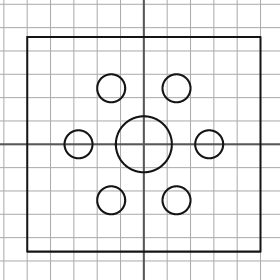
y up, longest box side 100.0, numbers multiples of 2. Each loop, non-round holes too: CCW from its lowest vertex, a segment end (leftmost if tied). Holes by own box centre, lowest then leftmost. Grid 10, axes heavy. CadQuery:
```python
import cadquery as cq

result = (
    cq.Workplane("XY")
    .moveTo(-50.0, -46.0)
    .lineTo(50.0, -46.0)
    .lineTo(50.0, 46.0)
    .lineTo(-50.0, 46.0)
    .close()
    .moveTo(-14.0, -24.0)
    .circle(6.0)
    .moveTo(14.0, -24.0)
    .circle(6.0)
    .moveTo(-28.0, 0.0)
    .circle(6.0)
    .moveTo(0.0, 0.0)
    .circle(12.0)
    .moveTo(28.0, 0.0)
    .circle(6.0)
    .moveTo(-14.0, 24.0)
    .circle(6.0)
    .moveTo(14.0, 24.0)
    .circle(6.0)
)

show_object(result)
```